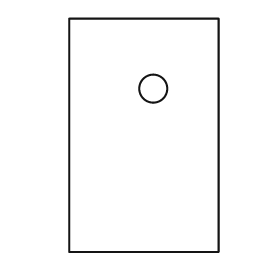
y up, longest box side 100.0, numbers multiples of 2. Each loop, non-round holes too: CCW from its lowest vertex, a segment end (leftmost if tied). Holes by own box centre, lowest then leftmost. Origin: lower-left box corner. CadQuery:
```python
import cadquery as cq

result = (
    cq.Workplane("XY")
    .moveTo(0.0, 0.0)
    .lineTo(64.0, 0.0)
    .lineTo(64.0, 100.0)
    .lineTo(0.0, 100.0)
    .close()
    .moveTo(36.0, 70.0)
    .circle(6.0)
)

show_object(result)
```